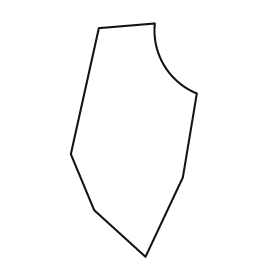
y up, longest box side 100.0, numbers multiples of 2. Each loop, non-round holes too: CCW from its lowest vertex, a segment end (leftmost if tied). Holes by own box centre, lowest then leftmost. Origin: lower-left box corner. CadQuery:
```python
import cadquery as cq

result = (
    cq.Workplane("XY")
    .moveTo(32.0, 0.0)
    .lineTo(48.0, 34.0)
    .lineTo(54.0, 70.0)
    .threePointArc((40.0, 82.0), (36.0, 100.0))
    .lineTo(12.0, 98.0)
    .lineTo(0.0, 44.0)
    .lineTo(10.0, 20.0)
    .close()
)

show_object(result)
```